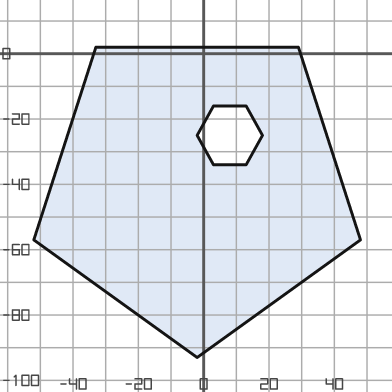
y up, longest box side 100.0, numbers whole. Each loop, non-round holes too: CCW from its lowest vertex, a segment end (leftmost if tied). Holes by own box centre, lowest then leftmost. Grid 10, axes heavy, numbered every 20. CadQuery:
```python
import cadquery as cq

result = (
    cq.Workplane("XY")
    .moveTo(-2.0, -93.0)
    .lineTo(48.0, -57.0)
    .lineTo(29.0, 2.0)
    .lineTo(-33.0, 2.0)
    .lineTo(-52.0, -57.0)
    .close()
    .moveTo(3.0, -34.0)
    .lineTo(13.0, -34.0)
    .lineTo(18.0, -25.0)
    .lineTo(13.0, -16.0)
    .lineTo(3.0, -16.0)
    .lineTo(-2.0, -25.0)
    .close()
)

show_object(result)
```